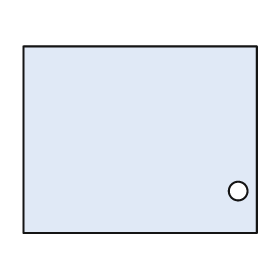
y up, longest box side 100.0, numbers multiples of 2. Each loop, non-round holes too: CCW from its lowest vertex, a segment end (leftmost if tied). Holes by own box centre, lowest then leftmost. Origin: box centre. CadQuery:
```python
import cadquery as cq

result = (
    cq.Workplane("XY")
    .moveTo(-50.0, -40.0)
    .lineTo(50.0, -40.0)
    .lineTo(50.0, 40.0)
    .lineTo(-50.0, 40.0)
    .close()
    .moveTo(42.0, -22.0)
    .circle(4.0)
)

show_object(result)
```